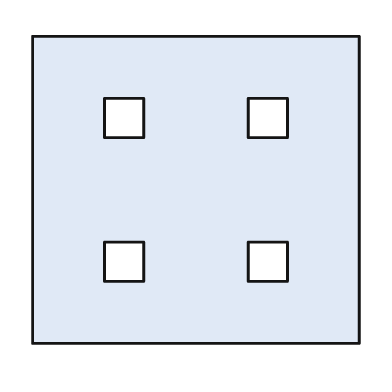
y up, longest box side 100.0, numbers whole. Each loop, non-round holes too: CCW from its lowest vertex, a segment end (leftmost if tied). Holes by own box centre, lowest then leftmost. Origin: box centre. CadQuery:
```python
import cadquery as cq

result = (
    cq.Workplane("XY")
    .moveTo(-50.0, -47.0)
    .lineTo(50.0, -47.0)
    .lineTo(50.0, 47.0)
    .lineTo(-50.0, 47.0)
    .close()
    .moveTo(-28.0, -28.0)
    .lineTo(-16.0, -28.0)
    .lineTo(-16.0, -16.0)
    .lineTo(-28.0, -16.0)
    .close()
    .moveTo(16.0, -28.0)
    .lineTo(28.0, -28.0)
    .lineTo(28.0, -16.0)
    .lineTo(16.0, -16.0)
    .close()
    .moveTo(-28.0, 16.0)
    .lineTo(-16.0, 16.0)
    .lineTo(-16.0, 28.0)
    .lineTo(-28.0, 28.0)
    .close()
    .moveTo(16.0, 16.0)
    .lineTo(28.0, 16.0)
    .lineTo(28.0, 28.0)
    .lineTo(16.0, 28.0)
    .close()
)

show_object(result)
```